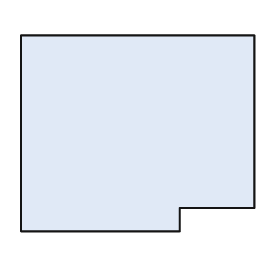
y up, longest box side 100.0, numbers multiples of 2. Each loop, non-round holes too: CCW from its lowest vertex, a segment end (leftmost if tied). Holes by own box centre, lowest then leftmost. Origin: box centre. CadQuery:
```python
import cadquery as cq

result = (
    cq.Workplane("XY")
    .moveTo(-50.0, -42.0)
    .lineTo(18.0, -42.0)
    .lineTo(18.0, -32.0)
    .lineTo(50.0, -32.0)
    .lineTo(50.0, 42.0)
    .lineTo(-50.0, 42.0)
    .close()
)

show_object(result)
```